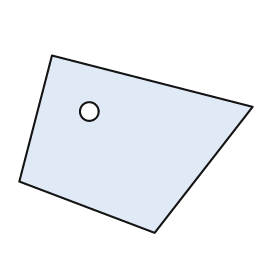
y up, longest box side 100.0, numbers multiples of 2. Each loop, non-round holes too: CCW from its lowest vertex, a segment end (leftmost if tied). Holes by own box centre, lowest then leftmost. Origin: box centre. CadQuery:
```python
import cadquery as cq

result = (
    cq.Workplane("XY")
    .moveTo(8.0, -38.0)
    .lineTo(50.0, 16.0)
    .lineTo(-36.0, 38.0)
    .lineTo(-50.0, -16.0)
    .close()
    .moveTo(-20.0, 14.0)
    .circle(4.0)
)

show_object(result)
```